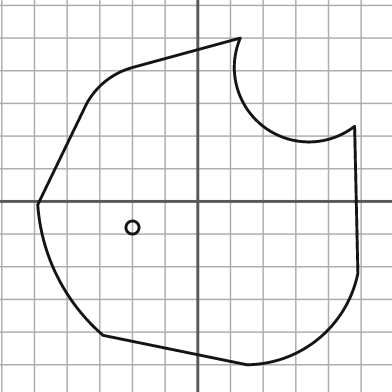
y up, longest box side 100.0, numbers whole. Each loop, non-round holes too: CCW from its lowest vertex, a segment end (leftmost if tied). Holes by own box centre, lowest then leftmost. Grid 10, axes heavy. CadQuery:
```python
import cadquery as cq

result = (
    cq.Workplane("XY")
    .moveTo(15.0, -50.0)
    .threePointArc((37.0, -42.0), (49.0, -22.0))
    .lineTo(48.0, 23.0)
    .threePointArc((20.0, 23.0), (13.0, 50.0))
    .lineTo(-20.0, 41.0)
    .threePointArc((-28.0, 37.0), (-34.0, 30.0))
    .lineTo(-49.0, -1.0)
    .threePointArc((-43.0, -23.0), (-29.0, -41.0))
    .close()
    .moveTo(-20.0, -8.0)
    .circle(2.0)
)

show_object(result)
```